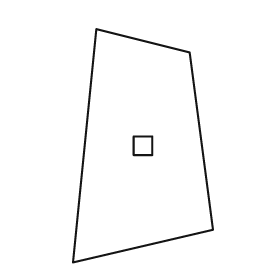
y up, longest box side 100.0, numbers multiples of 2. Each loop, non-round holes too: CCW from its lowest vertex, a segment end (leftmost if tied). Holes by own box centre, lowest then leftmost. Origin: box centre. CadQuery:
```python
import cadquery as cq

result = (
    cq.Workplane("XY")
    .moveTo(-30.0, -50.0)
    .lineTo(30.0, -36.0)
    .lineTo(20.0, 40.0)
    .lineTo(-20.0, 50.0)
    .close()
    .moveTo(-4.0, -4.0)
    .lineTo(4.0, -4.0)
    .lineTo(4.0, 4.0)
    .lineTo(-4.0, 4.0)
    .close()
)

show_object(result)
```